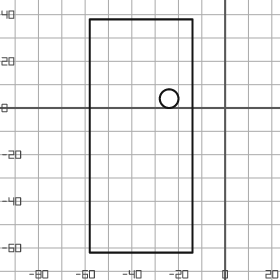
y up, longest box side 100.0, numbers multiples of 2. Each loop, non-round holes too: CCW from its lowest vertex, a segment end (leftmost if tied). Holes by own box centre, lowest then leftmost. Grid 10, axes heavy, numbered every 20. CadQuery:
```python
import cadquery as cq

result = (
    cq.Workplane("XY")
    .moveTo(-58.0, -62.0)
    .lineTo(-14.0, -62.0)
    .lineTo(-14.0, 38.0)
    .lineTo(-58.0, 38.0)
    .close()
    .moveTo(-24.0, 4.0)
    .circle(4.0)
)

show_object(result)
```